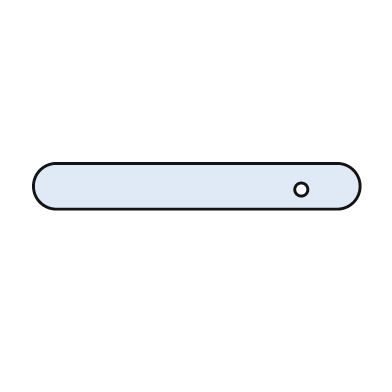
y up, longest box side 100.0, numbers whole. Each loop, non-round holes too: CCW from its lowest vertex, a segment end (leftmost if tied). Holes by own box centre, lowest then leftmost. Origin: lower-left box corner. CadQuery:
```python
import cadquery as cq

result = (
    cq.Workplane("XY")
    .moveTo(7.0, 0.0)
    .lineTo(93.0, 0.0)
    .threePointArc((100.0, 7.0), (93.0, 14.0))
    .lineTo(7.0, 14.0)
    .threePointArc((0.0, 7.0), (7.0, 0.0))
    .close()
    .moveTo(82.0, 6.0)
    .circle(2.0)
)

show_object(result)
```